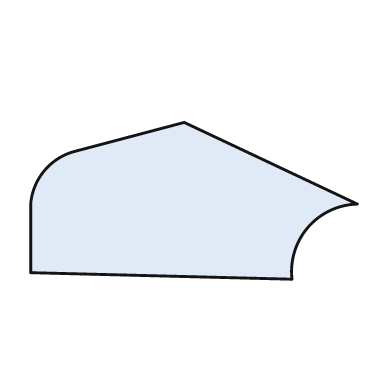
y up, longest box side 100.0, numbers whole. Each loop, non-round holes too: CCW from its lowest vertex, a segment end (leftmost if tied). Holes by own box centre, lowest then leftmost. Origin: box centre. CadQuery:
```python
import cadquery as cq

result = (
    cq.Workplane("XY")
    .moveTo(30.0, -24.0)
    .threePointArc((35.0, -8.0), (50.0, -1.0))
    .lineTo(-3.0, 24.0)
    .lineTo(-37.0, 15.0)
    .threePointArc((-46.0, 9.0), (-50.0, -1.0))
    .lineTo(-50.0, -22.0)
    .close()
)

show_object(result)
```